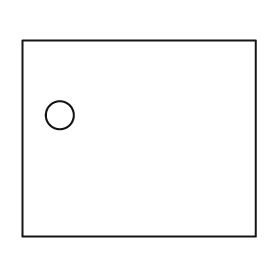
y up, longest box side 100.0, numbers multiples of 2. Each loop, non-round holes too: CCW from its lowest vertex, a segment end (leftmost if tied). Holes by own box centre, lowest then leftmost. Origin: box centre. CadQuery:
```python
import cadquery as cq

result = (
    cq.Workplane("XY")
    .moveTo(-50.0, -42.0)
    .lineTo(50.0, -42.0)
    .lineTo(50.0, 42.0)
    .lineTo(-50.0, 42.0)
    .close()
    .moveTo(-34.0, 10.0)
    .circle(6.0)
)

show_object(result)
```